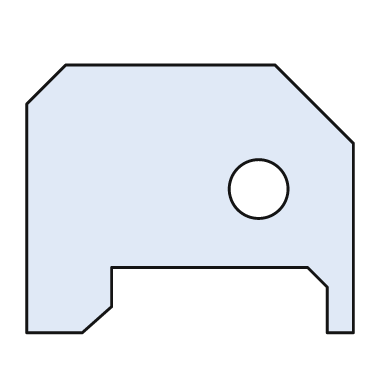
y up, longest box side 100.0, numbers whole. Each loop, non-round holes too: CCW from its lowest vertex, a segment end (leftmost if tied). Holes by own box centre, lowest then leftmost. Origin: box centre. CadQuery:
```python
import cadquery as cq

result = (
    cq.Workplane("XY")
    .moveTo(-50.0, -41.0)
    .lineTo(-33.0, -41.0)
    .lineTo(-24.0, -33.0)
    .lineTo(-24.0, -21.0)
    .lineTo(36.0, -21.0)
    .lineTo(42.0, -27.0)
    .lineTo(42.0, -41.0)
    .lineTo(50.0, -41.0)
    .lineTo(50.0, 17.0)
    .lineTo(26.0, 41.0)
    .lineTo(-38.0, 41.0)
    .lineTo(-50.0, 29.0)
    .close()
    .moveTo(21.0, 3.0)
    .circle(9.0)
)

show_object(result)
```